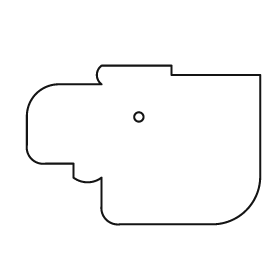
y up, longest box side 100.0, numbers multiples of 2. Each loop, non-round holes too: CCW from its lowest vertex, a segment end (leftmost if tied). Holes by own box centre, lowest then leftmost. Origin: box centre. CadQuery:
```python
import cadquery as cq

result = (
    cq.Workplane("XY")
    .moveTo(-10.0, -34.0)
    .lineTo(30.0, -34.0)
    .threePointArc((44.0, -28.0), (50.0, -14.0))
    .lineTo(50.0, 30.0)
    .lineTo(12.0, 30.0)
    .lineTo(12.0, 34.0)
    .lineTo(-18.0, 34.0)
    .threePointArc((-20.0, 30.0), (-18.0, 26.0))
    .lineTo(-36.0, 26.0)
    .threePointArc((-46.0, 22.0), (-50.0, 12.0))
    .lineTo(-50.0, 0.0)
    .threePointArc((-48.0, -6.0), (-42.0, -8.0))
    .lineTo(-30.0, -8.0)
    .lineTo(-30.0, -14.0)
    .threePointArc((-24.0, -16.0), (-18.0, -14.0))
    .lineTo(-18.0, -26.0)
    .threePointArc((-16.0, -32.0), (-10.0, -34.0))
    .close()
    .moveTo(-2.0, 12.0)
    .circle(2.0)
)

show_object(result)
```